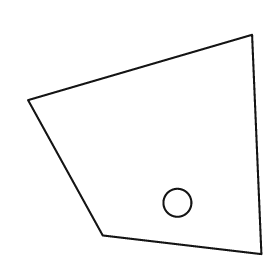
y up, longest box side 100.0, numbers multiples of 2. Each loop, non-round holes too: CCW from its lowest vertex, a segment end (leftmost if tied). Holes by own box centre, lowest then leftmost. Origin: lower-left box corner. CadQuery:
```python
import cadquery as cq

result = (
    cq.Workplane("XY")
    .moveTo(100.0, 0.0)
    .lineTo(96.0, 94.0)
    .lineTo(0.0, 66.0)
    .lineTo(32.0, 8.0)
    .close()
    .moveTo(64.0, 22.0)
    .circle(6.0)
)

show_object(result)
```